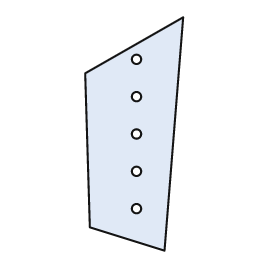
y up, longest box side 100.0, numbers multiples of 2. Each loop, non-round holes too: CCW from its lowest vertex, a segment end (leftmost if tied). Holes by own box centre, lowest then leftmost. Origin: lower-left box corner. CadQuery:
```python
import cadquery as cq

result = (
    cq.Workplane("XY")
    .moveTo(34.0, 0.0)
    .lineTo(42.0, 100.0)
    .lineTo(0.0, 76.0)
    .lineTo(2.0, 10.0)
    .close()
    .moveTo(22.0, 18.0)
    .circle(2.0)
    .moveTo(22.0, 34.0)
    .circle(2.0)
    .moveTo(22.0, 50.0)
    .circle(2.0)
    .moveTo(22.0, 66.0)
    .circle(2.0)
    .moveTo(22.0, 82.0)
    .circle(2.0)
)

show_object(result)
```